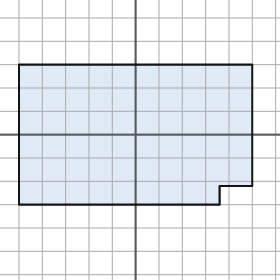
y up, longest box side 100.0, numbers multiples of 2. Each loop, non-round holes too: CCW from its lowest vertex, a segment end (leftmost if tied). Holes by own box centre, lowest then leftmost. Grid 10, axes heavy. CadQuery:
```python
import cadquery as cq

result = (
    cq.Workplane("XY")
    .moveTo(-50.0, -30.0)
    .lineTo(36.0, -30.0)
    .lineTo(36.0, -22.0)
    .lineTo(50.0, -22.0)
    .lineTo(50.0, 30.0)
    .lineTo(-50.0, 30.0)
    .close()
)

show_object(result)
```